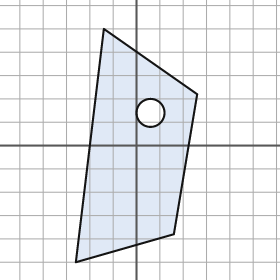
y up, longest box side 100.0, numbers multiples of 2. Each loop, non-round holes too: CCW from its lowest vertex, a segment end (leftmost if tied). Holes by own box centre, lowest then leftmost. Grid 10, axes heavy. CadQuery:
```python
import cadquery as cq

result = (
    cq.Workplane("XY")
    .moveTo(-26.0, -50.0)
    .lineTo(16.0, -38.0)
    .lineTo(26.0, 22.0)
    .lineTo(-14.0, 50.0)
    .close()
    .moveTo(6.0, 14.0)
    .circle(6.0)
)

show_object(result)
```